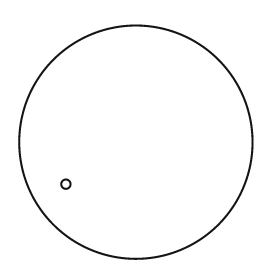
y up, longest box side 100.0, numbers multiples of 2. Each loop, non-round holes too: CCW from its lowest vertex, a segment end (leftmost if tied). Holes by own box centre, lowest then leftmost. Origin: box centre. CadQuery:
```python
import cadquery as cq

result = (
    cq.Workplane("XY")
    .moveTo(0.0, 0.0)
    .circle(50.0)
    .moveTo(-30.0, -18.0)
    .circle(2.0)
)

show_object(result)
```